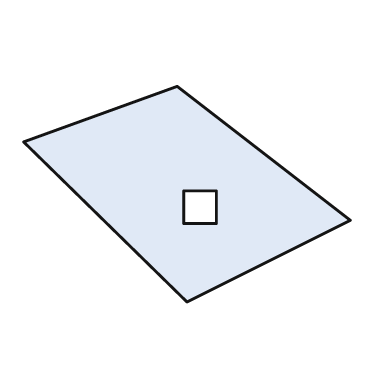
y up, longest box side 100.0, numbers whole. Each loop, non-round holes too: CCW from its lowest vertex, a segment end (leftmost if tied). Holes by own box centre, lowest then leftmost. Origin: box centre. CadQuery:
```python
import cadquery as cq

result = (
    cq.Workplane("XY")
    .moveTo(0.0, -33.0)
    .lineTo(50.0, -8.0)
    .lineTo(-3.0, 33.0)
    .lineTo(-50.0, 16.0)
    .close()
    .moveTo(-1.0, -9.0)
    .lineTo(9.0, -9.0)
    .lineTo(9.0, 1.0)
    .lineTo(-1.0, 1.0)
    .close()
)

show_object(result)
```